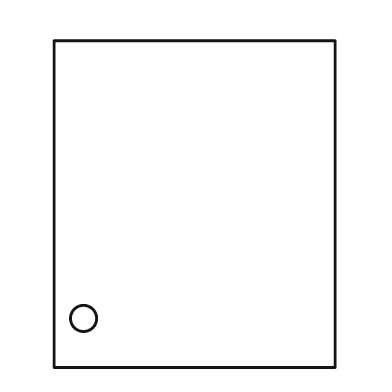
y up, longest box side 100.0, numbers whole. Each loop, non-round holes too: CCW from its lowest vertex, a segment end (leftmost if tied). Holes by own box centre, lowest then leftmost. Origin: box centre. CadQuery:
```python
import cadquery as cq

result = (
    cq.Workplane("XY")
    .moveTo(-43.0, -50.0)
    .lineTo(43.0, -50.0)
    .lineTo(43.0, 50.0)
    .lineTo(-43.0, 50.0)
    .close()
    .moveTo(-34.0, -35.0)
    .circle(4.0)
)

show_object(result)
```